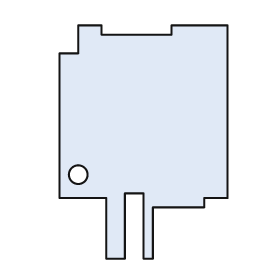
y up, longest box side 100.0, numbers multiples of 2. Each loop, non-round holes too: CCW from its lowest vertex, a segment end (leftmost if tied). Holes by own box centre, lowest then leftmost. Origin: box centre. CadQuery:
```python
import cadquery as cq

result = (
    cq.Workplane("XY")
    .moveTo(-16.0, -50.0)
    .lineTo(-8.0, -50.0)
    .lineTo(-8.0, -22.0)
    .lineTo(0.0, -22.0)
    .lineTo(0.0, -50.0)
    .lineTo(4.0, -50.0)
    .lineTo(4.0, -28.0)
    .lineTo(26.0, -28.0)
    .lineTo(26.0, -24.0)
    .lineTo(36.0, -24.0)
    .lineTo(36.0, 50.0)
    .lineTo(12.0, 50.0)
    .lineTo(12.0, 46.0)
    .lineTo(-18.0, 46.0)
    .lineTo(-18.0, 50.0)
    .lineTo(-28.0, 50.0)
    .lineTo(-28.0, 38.0)
    .lineTo(-36.0, 38.0)
    .lineTo(-36.0, -24.0)
    .lineTo(-16.0, -24.0)
    .close()
    .moveTo(-28.0, -14.0)
    .circle(4.0)
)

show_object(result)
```